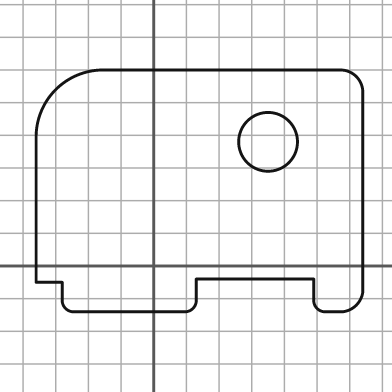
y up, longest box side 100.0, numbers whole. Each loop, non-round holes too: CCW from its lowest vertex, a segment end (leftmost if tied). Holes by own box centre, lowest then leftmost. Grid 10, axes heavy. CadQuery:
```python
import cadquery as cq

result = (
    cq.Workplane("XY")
    .moveTo(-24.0, -14.0)
    .lineTo(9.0, -14.0)
    .threePointArc((12.0, -13.0), (13.0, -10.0))
    .lineTo(13.0, -4.0)
    .lineTo(49.0, -4.0)
    .lineTo(49.0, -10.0)
    .threePointArc((50.0, -13.0), (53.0, -14.0))
    .lineTo(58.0, -14.0)
    .threePointArc((62.0, -12.0), (64.0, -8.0))
    .lineTo(64.0, 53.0)
    .threePointArc((62.0, 58.0), (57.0, 60.0))
    .lineTo(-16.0, 60.0)
    .threePointArc((-30.0, 54.0), (-36.0, 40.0))
    .lineTo(-36.0, -5.0)
    .lineTo(-28.0, -5.0)
    .lineTo(-28.0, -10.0)
    .threePointArc((-27.0, -13.0), (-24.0, -14.0))
    .close()
    .moveTo(35.0, 38.0)
    .circle(9.0)
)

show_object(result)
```